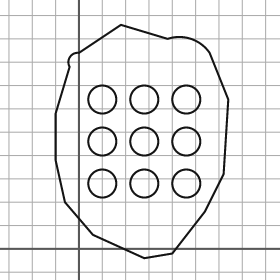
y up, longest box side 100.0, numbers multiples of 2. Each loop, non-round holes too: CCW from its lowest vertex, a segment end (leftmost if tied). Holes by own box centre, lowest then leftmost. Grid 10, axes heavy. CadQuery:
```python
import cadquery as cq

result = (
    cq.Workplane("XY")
    .moveTo(28.0, -4.0)
    .lineTo(40.0, -2.0)
    .lineTo(54.0, 16.0)
    .lineTo(62.0, 32.0)
    .lineTo(64.0, 64.0)
    .lineTo(56.0, 84.0)
    .threePointArc((48.0, 90.0), (38.0, 90.0))
    .lineTo(18.0, 96.0)
    .lineTo(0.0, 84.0)
    .threePointArc((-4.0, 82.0), (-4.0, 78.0))
    .lineTo(-10.0, 58.0)
    .lineTo(-10.0, 38.0)
    .lineTo(-6.0, 20.0)
    .lineTo(6.0, 6.0)
    .close()
    .moveTo(10.0, 28.0)
    .circle(6.0)
    .moveTo(28.0, 28.0)
    .circle(6.0)
    .moveTo(46.0, 28.0)
    .circle(6.0)
    .moveTo(10.0, 46.0)
    .circle(6.0)
    .moveTo(28.0, 46.0)
    .circle(6.0)
    .moveTo(46.0, 46.0)
    .circle(6.0)
    .moveTo(10.0, 64.0)
    .circle(6.0)
    .moveTo(28.0, 64.0)
    .circle(6.0)
    .moveTo(46.0, 64.0)
    .circle(6.0)
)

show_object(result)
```